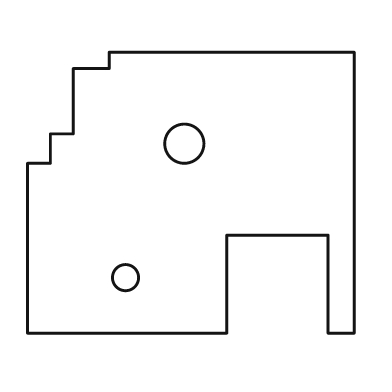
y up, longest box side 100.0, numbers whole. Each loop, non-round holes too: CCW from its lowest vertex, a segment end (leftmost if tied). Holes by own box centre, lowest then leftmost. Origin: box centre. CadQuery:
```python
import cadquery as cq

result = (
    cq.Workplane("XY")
    .moveTo(-50.0, -43.0)
    .lineTo(11.0, -43.0)
    .lineTo(11.0, -13.0)
    .lineTo(42.0, -13.0)
    .lineTo(42.0, -43.0)
    .lineTo(50.0, -43.0)
    .lineTo(50.0, 43.0)
    .lineTo(-25.0, 43.0)
    .lineTo(-25.0, 38.0)
    .lineTo(-36.0, 38.0)
    .lineTo(-36.0, 18.0)
    .lineTo(-43.0, 18.0)
    .lineTo(-43.0, 9.0)
    .lineTo(-50.0, 9.0)
    .close()
    .moveTo(-20.0, -26.0)
    .circle(4.0)
    .moveTo(-2.0, 15.0)
    .circle(6.0)
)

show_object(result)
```